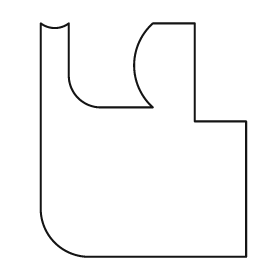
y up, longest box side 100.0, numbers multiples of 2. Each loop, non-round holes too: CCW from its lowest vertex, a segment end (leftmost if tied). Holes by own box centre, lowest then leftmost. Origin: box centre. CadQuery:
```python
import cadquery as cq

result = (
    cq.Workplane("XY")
    .moveTo(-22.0, -50.0)
    .lineTo(44.0, -50.0)
    .lineTo(44.0, 8.0)
    .lineTo(22.0, 8.0)
    .lineTo(22.0, 50.0)
    .lineTo(4.0, 50.0)
    .threePointArc((-4.0, 32.0), (4.0, 14.0))
    .lineTo(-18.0, 14.0)
    .threePointArc((-28.0, 18.0), (-32.0, 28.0))
    .lineTo(-32.0, 50.0)
    .threePointArc((-38.0, 48.0), (-44.0, 50.0))
    .lineTo(-44.0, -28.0)
    .threePointArc((-38.0, -44.0), (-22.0, -50.0))
    .close()
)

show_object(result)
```